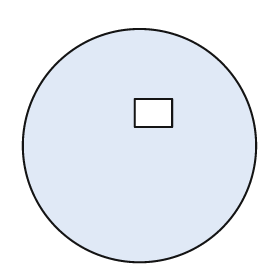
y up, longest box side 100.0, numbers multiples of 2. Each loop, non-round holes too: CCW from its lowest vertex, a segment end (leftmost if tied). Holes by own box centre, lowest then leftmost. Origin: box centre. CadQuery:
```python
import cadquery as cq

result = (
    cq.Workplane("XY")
    .moveTo(0.0, 0.0)
    .circle(50.0)
    .moveTo(-2.0, 8.0)
    .lineTo(14.0, 8.0)
    .lineTo(14.0, 20.0)
    .lineTo(-2.0, 20.0)
    .close()
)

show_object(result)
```